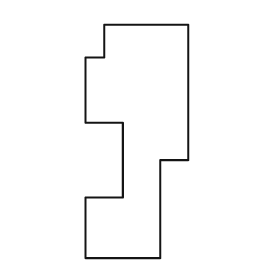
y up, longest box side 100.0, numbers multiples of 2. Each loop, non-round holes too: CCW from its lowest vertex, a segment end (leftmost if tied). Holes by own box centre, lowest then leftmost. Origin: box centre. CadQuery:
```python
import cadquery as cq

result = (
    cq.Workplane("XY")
    .moveTo(-22.0, -50.0)
    .lineTo(10.0, -50.0)
    .lineTo(10.0, -8.0)
    .lineTo(22.0, -8.0)
    .lineTo(22.0, 50.0)
    .lineTo(-14.0, 50.0)
    .lineTo(-14.0, 36.0)
    .lineTo(-22.0, 36.0)
    .lineTo(-22.0, 8.0)
    .lineTo(-6.0, 8.0)
    .lineTo(-6.0, -24.0)
    .lineTo(-22.0, -24.0)
    .close()
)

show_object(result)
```